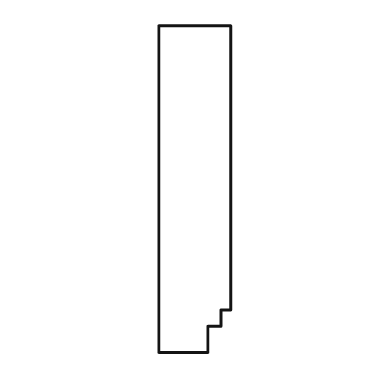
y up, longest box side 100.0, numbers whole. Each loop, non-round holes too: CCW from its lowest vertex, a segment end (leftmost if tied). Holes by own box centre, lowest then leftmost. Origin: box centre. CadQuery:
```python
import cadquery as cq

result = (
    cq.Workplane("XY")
    .moveTo(-11.0, -50.0)
    .lineTo(4.0, -50.0)
    .lineTo(4.0, -42.0)
    .lineTo(8.0, -42.0)
    .lineTo(8.0, -37.0)
    .lineTo(11.0, -37.0)
    .lineTo(11.0, 50.0)
    .lineTo(-11.0, 50.0)
    .close()
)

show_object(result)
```